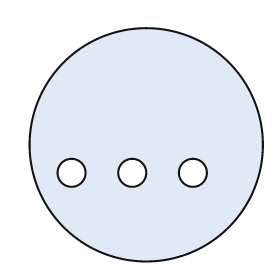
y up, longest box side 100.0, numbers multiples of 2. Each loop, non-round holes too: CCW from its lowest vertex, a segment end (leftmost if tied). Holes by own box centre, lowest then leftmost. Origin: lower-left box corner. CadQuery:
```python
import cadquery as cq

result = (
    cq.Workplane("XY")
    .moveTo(50.0, 50.0)
    .circle(50.0)
    .moveTo(18.0, 38.0)
    .circle(6.0)
    .moveTo(44.0, 38.0)
    .circle(6.0)
    .moveTo(70.0, 38.0)
    .circle(6.0)
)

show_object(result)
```